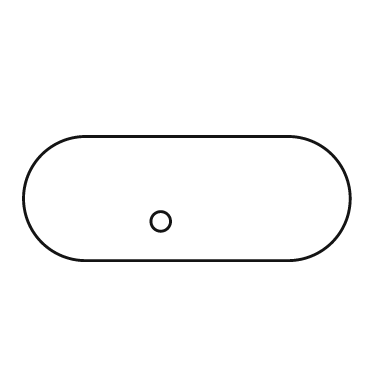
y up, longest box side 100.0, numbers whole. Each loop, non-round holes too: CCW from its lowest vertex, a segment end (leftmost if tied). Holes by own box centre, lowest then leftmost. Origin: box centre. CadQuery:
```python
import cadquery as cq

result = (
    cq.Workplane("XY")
    .moveTo(-31.0, -19.0)
    .lineTo(31.0, -19.0)
    .threePointArc((50.0, 0.0), (31.0, 19.0))
    .lineTo(-31.0, 19.0)
    .threePointArc((-50.0, 0.0), (-31.0, -19.0))
    .close()
    .moveTo(-8.0, -7.0)
    .circle(3.0)
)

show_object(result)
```